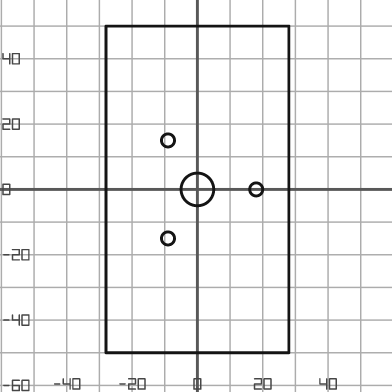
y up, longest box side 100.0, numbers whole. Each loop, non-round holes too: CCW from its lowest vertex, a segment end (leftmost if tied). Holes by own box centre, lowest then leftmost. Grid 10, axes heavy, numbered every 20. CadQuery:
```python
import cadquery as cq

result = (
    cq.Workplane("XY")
    .moveTo(-28.0, -50.0)
    .lineTo(28.0, -50.0)
    .lineTo(28.0, 50.0)
    .lineTo(-28.0, 50.0)
    .close()
    .moveTo(-9.0, -15.0)
    .circle(2.0)
    .moveTo(0.0, 0.0)
    .circle(5.0)
    .moveTo(18.0, 0.0)
    .circle(2.0)
    .moveTo(-9.0, 15.0)
    .circle(2.0)
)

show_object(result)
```